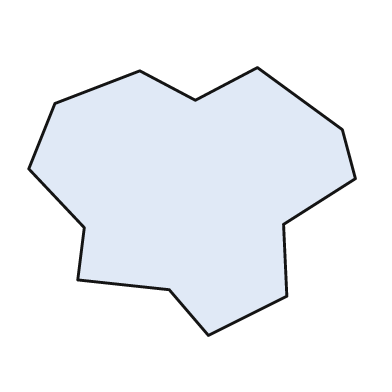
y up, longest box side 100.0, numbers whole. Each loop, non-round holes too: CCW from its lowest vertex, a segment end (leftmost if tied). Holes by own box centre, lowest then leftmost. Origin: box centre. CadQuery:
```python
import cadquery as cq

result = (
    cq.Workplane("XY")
    .moveTo(5.0, -41.0)
    .lineTo(29.0, -29.0)
    .lineTo(28.0, -7.0)
    .lineTo(50.0, 7.0)
    .lineTo(46.0, 22.0)
    .lineTo(20.0, 41.0)
    .lineTo(1.0, 31.0)
    .lineTo(-16.0, 40.0)
    .lineTo(-42.0, 30.0)
    .lineTo(-50.0, 10.0)
    .lineTo(-33.0, -8.0)
    .lineTo(-35.0, -24.0)
    .lineTo(-7.0, -27.0)
    .close()
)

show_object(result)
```